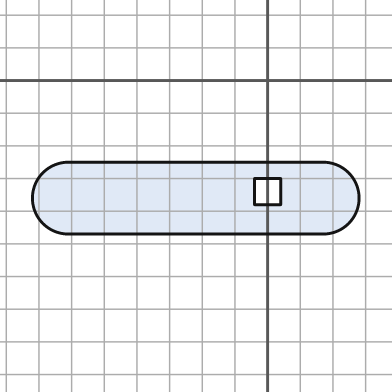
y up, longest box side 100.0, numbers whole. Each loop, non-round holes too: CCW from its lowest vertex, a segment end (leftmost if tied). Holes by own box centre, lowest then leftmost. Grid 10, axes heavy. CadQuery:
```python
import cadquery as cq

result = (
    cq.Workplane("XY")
    .moveTo(-61.0, -47.0)
    .lineTo(17.0, -47.0)
    .threePointArc((28.0, -36.0), (17.0, -25.0))
    .lineTo(-61.0, -25.0)
    .threePointArc((-72.0, -36.0), (-61.0, -47.0))
    .close()
    .moveTo(-4.0, -38.0)
    .lineTo(4.0, -38.0)
    .lineTo(4.0, -30.0)
    .lineTo(-4.0, -30.0)
    .close()
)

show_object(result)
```